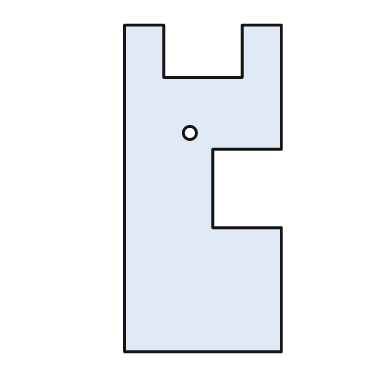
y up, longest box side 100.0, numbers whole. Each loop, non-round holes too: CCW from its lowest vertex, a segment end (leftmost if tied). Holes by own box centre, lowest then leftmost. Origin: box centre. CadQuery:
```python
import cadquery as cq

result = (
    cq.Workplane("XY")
    .moveTo(-24.0, -50.0)
    .lineTo(24.0, -50.0)
    .lineTo(24.0, -12.0)
    .lineTo(3.0, -12.0)
    .lineTo(3.0, 12.0)
    .lineTo(24.0, 12.0)
    .lineTo(24.0, 50.0)
    .lineTo(12.0, 50.0)
    .lineTo(12.0, 34.0)
    .lineTo(-12.0, 34.0)
    .lineTo(-12.0, 50.0)
    .lineTo(-24.0, 50.0)
    .close()
    .moveTo(-4.0, 17.0)
    .circle(2.0)
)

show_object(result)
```